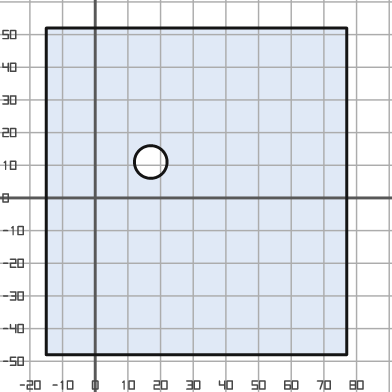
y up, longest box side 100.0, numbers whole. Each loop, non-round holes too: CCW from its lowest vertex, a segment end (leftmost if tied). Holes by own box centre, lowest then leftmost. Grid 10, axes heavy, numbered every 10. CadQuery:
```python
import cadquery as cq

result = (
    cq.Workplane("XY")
    .moveTo(-15.0, -48.0)
    .lineTo(77.0, -48.0)
    .lineTo(77.0, 52.0)
    .lineTo(-15.0, 52.0)
    .close()
    .moveTo(17.0, 11.0)
    .circle(5.0)
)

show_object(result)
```